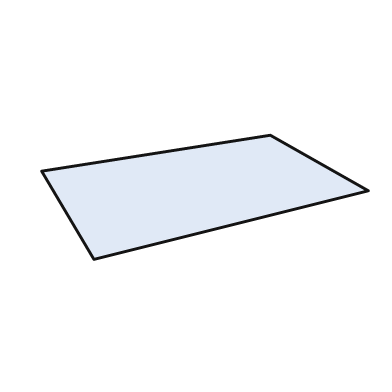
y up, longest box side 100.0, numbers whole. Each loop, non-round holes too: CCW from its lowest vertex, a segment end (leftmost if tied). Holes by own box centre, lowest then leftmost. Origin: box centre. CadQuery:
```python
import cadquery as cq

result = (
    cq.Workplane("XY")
    .moveTo(-34.0, -19.0)
    .lineTo(50.0, 2.0)
    .lineTo(20.0, 19.0)
    .lineTo(-50.0, 8.0)
    .close()
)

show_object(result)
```